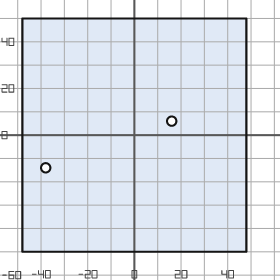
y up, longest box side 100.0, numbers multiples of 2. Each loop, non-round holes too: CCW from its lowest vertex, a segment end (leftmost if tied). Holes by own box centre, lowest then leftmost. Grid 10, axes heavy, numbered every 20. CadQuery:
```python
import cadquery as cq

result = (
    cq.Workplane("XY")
    .moveTo(-48.0, -50.0)
    .lineTo(48.0, -50.0)
    .lineTo(48.0, 50.0)
    .lineTo(-48.0, 50.0)
    .close()
    .moveTo(-38.0, -14.0)
    .circle(2.0)
    .moveTo(16.0, 6.0)
    .circle(2.0)
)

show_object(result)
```